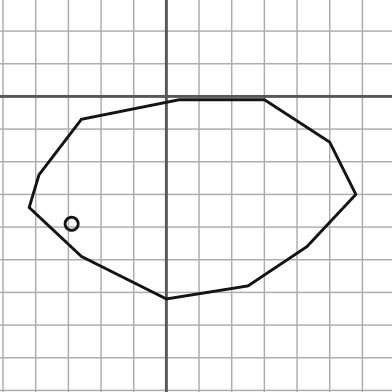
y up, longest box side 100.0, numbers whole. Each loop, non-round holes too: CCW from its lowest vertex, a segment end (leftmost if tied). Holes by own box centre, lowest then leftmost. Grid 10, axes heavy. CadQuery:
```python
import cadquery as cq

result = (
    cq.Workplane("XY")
    .moveTo(0.0, -62.0)
    .lineTo(25.0, -58.0)
    .lineTo(43.0, -46.0)
    .lineTo(58.0, -30.0)
    .lineTo(50.0, -14.0)
    .lineTo(30.0, -1.0)
    .lineTo(4.0, -1.0)
    .lineTo(-26.0, -7.0)
    .lineTo(-39.0, -24.0)
    .lineTo(-42.0, -34.0)
    .lineTo(-26.0, -49.0)
    .close()
    .moveTo(-29.0, -39.0)
    .circle(2.0)
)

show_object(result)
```